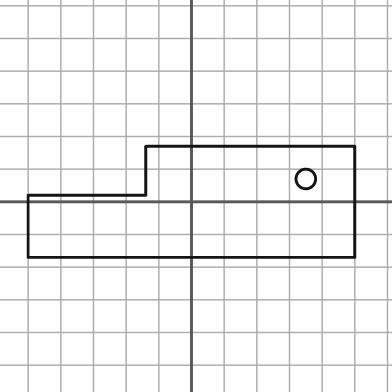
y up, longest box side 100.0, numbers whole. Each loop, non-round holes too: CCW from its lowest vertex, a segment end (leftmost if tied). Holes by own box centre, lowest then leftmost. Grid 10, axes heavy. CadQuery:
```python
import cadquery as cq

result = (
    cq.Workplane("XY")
    .moveTo(-50.0, -17.0)
    .lineTo(50.0, -17.0)
    .lineTo(50.0, 17.0)
    .lineTo(-14.0, 17.0)
    .lineTo(-14.0, 2.0)
    .lineTo(-50.0, 2.0)
    .close()
    .moveTo(35.0, 7.0)
    .circle(3.0)
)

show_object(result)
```